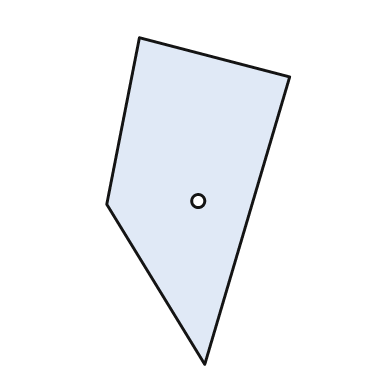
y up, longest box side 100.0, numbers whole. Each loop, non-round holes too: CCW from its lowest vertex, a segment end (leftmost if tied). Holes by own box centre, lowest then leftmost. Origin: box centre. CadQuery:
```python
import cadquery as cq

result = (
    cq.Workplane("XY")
    .moveTo(2.0, -50.0)
    .lineTo(28.0, 38.0)
    .lineTo(-18.0, 50.0)
    .lineTo(-28.0, -1.0)
    .close()
    .moveTo(0.0, 0.0)
    .circle(2.0)
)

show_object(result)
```